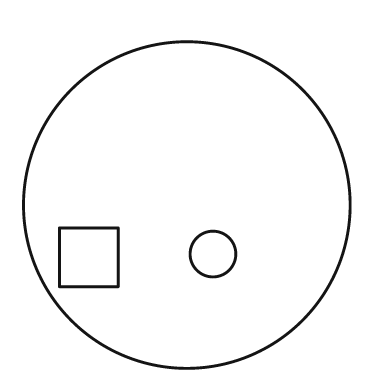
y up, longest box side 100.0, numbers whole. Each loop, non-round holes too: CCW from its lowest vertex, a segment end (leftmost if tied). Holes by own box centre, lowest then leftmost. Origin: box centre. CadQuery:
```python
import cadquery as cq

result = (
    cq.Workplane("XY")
    .moveTo(0.0, 0.0)
    .circle(50.0)
    .moveTo(-39.0, -25.0)
    .lineTo(-21.0, -25.0)
    .lineTo(-21.0, -7.0)
    .lineTo(-39.0, -7.0)
    .close()
    .moveTo(8.0, -15.0)
    .circle(7.0)
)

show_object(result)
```